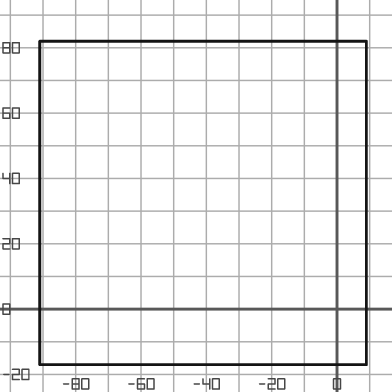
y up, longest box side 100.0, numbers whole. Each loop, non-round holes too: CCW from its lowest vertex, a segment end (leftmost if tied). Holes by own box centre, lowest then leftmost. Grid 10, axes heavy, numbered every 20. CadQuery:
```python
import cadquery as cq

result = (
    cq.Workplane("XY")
    .moveTo(-91.0, -17.0)
    .lineTo(9.0, -17.0)
    .lineTo(9.0, 82.0)
    .lineTo(-91.0, 82.0)
    .close()
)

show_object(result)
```